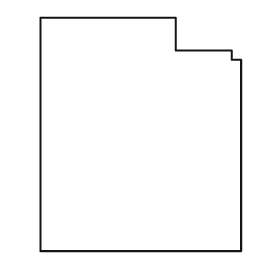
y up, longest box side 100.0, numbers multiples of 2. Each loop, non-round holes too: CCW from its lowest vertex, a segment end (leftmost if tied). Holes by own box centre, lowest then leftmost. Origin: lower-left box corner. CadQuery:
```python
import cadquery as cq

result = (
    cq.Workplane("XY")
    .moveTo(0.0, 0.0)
    .lineTo(86.0, 0.0)
    .lineTo(86.0, 82.0)
    .lineTo(82.0, 82.0)
    .lineTo(82.0, 86.0)
    .lineTo(58.0, 86.0)
    .lineTo(58.0, 100.0)
    .lineTo(0.0, 100.0)
    .close()
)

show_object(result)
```